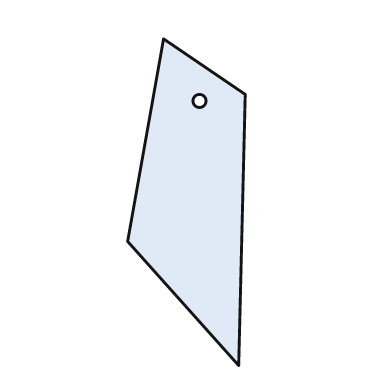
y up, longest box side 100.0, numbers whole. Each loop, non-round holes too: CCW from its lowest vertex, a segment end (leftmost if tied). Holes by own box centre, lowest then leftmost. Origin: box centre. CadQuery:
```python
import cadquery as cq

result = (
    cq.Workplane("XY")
    .moveTo(16.0, -50.0)
    .lineTo(18.0, 33.0)
    .lineTo(-7.0, 50.0)
    .lineTo(-18.0, -12.0)
    .close()
    .moveTo(4.0, 31.0)
    .circle(2.0)
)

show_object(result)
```